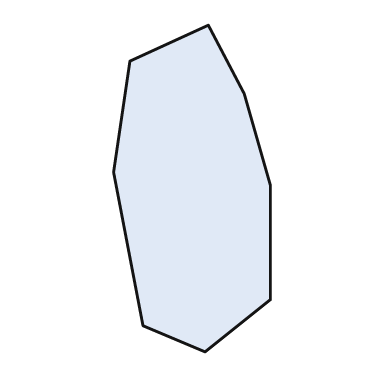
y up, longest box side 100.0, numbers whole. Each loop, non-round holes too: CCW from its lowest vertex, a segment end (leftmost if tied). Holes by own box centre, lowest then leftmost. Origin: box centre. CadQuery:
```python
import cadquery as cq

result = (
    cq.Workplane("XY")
    .moveTo(4.0, -50.0)
    .lineTo(24.0, -34.0)
    .lineTo(24.0, 1.0)
    .lineTo(16.0, 29.0)
    .lineTo(5.0, 50.0)
    .lineTo(-19.0, 39.0)
    .lineTo(-24.0, 5.0)
    .lineTo(-15.0, -42.0)
    .close()
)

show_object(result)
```